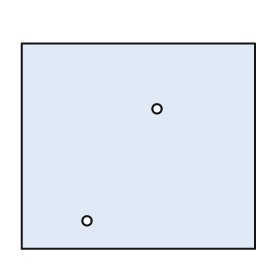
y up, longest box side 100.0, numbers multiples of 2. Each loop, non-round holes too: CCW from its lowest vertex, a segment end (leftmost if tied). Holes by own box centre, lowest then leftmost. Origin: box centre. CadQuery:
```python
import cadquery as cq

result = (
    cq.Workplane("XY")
    .moveTo(-50.0, -44.0)
    .lineTo(50.0, -44.0)
    .lineTo(50.0, 44.0)
    .lineTo(-50.0, 44.0)
    .close()
    .moveTo(-22.0, -32.0)
    .circle(2.0)
    .moveTo(8.0, 16.0)
    .circle(2.0)
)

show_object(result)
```